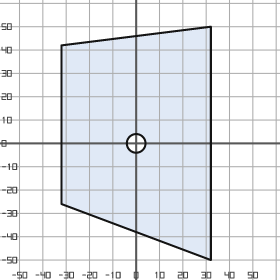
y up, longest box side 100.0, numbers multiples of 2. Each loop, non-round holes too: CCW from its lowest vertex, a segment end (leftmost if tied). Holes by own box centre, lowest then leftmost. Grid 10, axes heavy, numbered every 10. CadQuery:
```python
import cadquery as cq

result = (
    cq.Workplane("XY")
    .moveTo(32.0, -50.0)
    .lineTo(32.0, 50.0)
    .lineTo(-32.0, 42.0)
    .lineTo(-32.0, -26.0)
    .close()
    .moveTo(0.0, 0.0)
    .circle(4.0)
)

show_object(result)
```